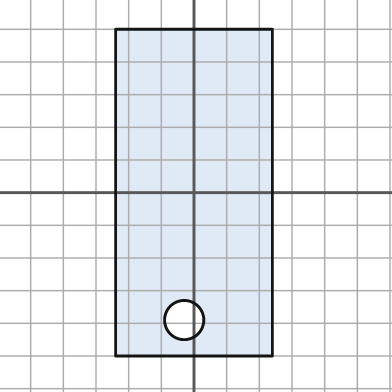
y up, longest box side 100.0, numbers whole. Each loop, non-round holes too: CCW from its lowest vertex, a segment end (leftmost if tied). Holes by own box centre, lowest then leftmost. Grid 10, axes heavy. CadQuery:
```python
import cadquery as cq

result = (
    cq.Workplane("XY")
    .moveTo(-24.0, -50.0)
    .lineTo(24.0, -50.0)
    .lineTo(24.0, 50.0)
    .lineTo(-24.0, 50.0)
    .close()
    .moveTo(-3.0, -39.0)
    .circle(6.0)
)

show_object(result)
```